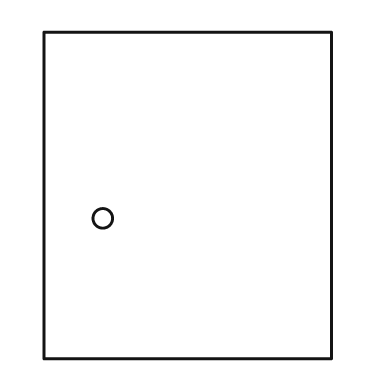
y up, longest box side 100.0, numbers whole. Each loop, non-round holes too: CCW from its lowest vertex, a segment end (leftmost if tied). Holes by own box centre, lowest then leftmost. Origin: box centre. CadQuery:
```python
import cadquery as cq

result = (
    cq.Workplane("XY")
    .moveTo(-44.0, -50.0)
    .lineTo(44.0, -50.0)
    .lineTo(44.0, 50.0)
    .lineTo(-44.0, 50.0)
    .close()
    .moveTo(-26.0, -7.0)
    .circle(3.0)
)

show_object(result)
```